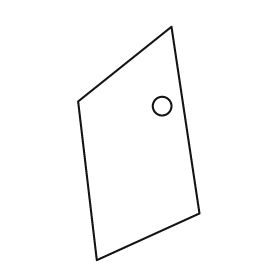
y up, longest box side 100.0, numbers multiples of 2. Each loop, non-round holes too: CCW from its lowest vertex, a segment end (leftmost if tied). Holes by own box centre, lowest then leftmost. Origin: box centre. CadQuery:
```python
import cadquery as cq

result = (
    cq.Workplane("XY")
    .moveTo(-18.0, -50.0)
    .lineTo(26.0, -30.0)
    .lineTo(14.0, 50.0)
    .lineTo(-26.0, 18.0)
    .close()
    .moveTo(10.0, 16.0)
    .circle(4.0)
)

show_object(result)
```